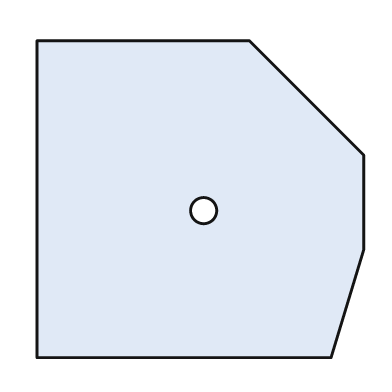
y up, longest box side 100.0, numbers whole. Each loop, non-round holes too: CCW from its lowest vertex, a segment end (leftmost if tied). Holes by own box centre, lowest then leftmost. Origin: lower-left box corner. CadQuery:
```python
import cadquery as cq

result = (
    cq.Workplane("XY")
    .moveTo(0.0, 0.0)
    .lineTo(90.0, 0.0)
    .lineTo(100.0, 33.0)
    .lineTo(100.0, 62.0)
    .lineTo(65.0, 97.0)
    .lineTo(0.0, 97.0)
    .close()
    .moveTo(51.0, 45.0)
    .circle(4.0)
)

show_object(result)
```